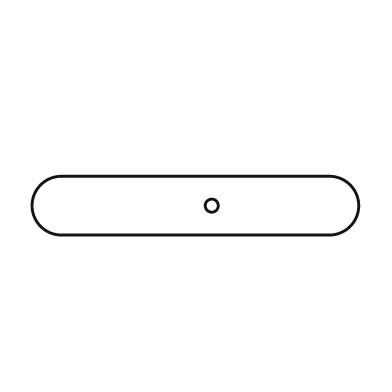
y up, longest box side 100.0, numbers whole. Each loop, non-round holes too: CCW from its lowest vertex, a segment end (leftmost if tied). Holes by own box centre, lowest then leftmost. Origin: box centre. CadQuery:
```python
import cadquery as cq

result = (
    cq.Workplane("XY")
    .moveTo(-41.0, -9.0)
    .lineTo(41.0, -9.0)
    .threePointArc((50.0, 0.0), (41.0, 9.0))
    .lineTo(-41.0, 9.0)
    .threePointArc((-50.0, 0.0), (-41.0, -9.0))
    .close()
    .moveTo(5.0, 0.0)
    .circle(2.0)
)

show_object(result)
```